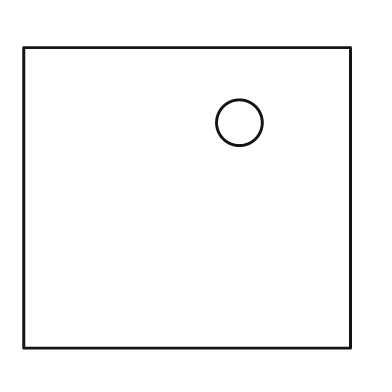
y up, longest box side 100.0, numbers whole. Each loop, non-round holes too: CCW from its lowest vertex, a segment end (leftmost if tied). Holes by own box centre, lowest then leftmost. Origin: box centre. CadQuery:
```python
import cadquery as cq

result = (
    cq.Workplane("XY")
    .moveTo(-50.0, -46.0)
    .lineTo(50.0, -46.0)
    .lineTo(50.0, 46.0)
    .lineTo(-50.0, 46.0)
    .close()
    .moveTo(16.0, 23.0)
    .circle(7.0)
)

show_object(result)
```